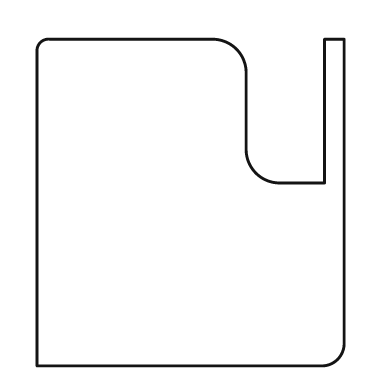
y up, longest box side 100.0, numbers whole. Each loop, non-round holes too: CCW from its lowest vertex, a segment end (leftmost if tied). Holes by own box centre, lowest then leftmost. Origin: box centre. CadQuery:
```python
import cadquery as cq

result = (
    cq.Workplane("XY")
    .moveTo(-47.0, -50.0)
    .lineTo(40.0, -50.0)
    .threePointArc((45.0, -48.0), (47.0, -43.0))
    .lineTo(47.0, 50.0)
    .lineTo(41.0, 50.0)
    .lineTo(41.0, 6.0)
    .lineTo(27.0, 6.0)
    .threePointArc((20.0, 9.0), (17.0, 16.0))
    .lineTo(17.0, 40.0)
    .threePointArc((14.0, 47.0), (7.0, 50.0))
    .lineTo(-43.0, 50.0)
    .threePointArc((-46.0, 49.0), (-47.0, 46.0))
    .close()
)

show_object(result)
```